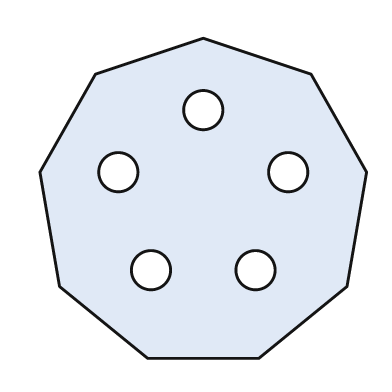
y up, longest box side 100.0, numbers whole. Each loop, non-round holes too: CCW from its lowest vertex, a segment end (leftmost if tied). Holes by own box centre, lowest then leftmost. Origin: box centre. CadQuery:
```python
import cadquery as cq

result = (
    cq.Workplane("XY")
    .moveTo(-17.0, -49.0)
    .lineTo(17.0, -49.0)
    .lineTo(44.0, -27.0)
    .lineTo(50.0, 8.0)
    .lineTo(33.0, 38.0)
    .lineTo(0.0, 49.0)
    .lineTo(-33.0, 38.0)
    .lineTo(-50.0, 8.0)
    .lineTo(-44.0, -27.0)
    .close()
    .moveTo(-16.0, -22.0)
    .circle(6.0)
    .moveTo(16.0, -22.0)
    .circle(6.0)
    .moveTo(-26.0, 8.0)
    .circle(6.0)
    .moveTo(26.0, 8.0)
    .circle(6.0)
    .moveTo(0.0, 27.0)
    .circle(6.0)
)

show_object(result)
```